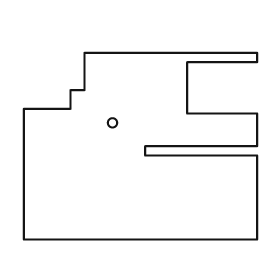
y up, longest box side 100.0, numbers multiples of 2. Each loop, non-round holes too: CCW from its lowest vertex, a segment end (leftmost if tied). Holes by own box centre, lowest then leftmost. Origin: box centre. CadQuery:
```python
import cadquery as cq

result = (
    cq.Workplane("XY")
    .moveTo(-50.0, -40.0)
    .lineTo(50.0, -40.0)
    .lineTo(50.0, -4.0)
    .lineTo(2.0, -4.0)
    .lineTo(2.0, 0.0)
    .lineTo(50.0, 0.0)
    .lineTo(50.0, 14.0)
    .lineTo(20.0, 14.0)
    .lineTo(20.0, 36.0)
    .lineTo(50.0, 36.0)
    .lineTo(50.0, 40.0)
    .lineTo(-24.0, 40.0)
    .lineTo(-24.0, 24.0)
    .lineTo(-30.0, 24.0)
    .lineTo(-30.0, 16.0)
    .lineTo(-50.0, 16.0)
    .close()
    .moveTo(-12.0, 10.0)
    .circle(2.0)
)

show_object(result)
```